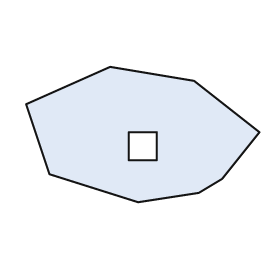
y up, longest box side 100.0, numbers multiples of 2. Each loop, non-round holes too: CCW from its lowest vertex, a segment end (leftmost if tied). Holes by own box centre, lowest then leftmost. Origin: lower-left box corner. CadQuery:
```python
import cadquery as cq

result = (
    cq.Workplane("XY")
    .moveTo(48.0, 0.0)
    .lineTo(74.0, 4.0)
    .lineTo(84.0, 10.0)
    .lineTo(100.0, 30.0)
    .lineTo(72.0, 52.0)
    .lineTo(36.0, 58.0)
    .lineTo(0.0, 42.0)
    .lineTo(10.0, 12.0)
    .close()
    .moveTo(44.0, 18.0)
    .lineTo(56.0, 18.0)
    .lineTo(56.0, 30.0)
    .lineTo(44.0, 30.0)
    .close()
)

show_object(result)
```